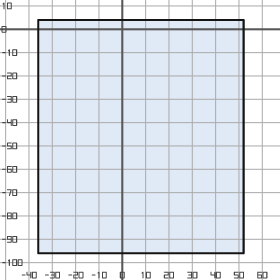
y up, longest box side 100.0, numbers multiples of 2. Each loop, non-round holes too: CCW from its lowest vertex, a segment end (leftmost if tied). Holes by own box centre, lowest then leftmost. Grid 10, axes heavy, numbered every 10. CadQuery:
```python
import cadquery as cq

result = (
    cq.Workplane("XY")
    .moveTo(-36.0, -96.0)
    .lineTo(52.0, -96.0)
    .lineTo(52.0, 4.0)
    .lineTo(-36.0, 4.0)
    .close()
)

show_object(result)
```